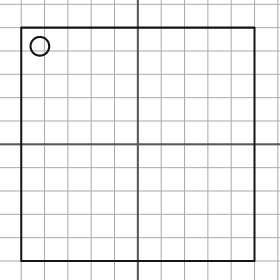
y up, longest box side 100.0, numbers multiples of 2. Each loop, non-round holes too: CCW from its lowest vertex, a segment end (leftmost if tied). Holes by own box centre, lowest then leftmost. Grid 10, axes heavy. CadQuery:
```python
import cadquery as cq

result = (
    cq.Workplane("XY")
    .moveTo(-50.0, -50.0)
    .lineTo(50.0, -50.0)
    .lineTo(50.0, 50.0)
    .lineTo(-50.0, 50.0)
    .close()
    .moveTo(-42.0, 42.0)
    .circle(4.0)
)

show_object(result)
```